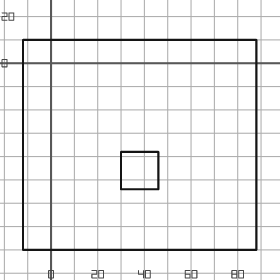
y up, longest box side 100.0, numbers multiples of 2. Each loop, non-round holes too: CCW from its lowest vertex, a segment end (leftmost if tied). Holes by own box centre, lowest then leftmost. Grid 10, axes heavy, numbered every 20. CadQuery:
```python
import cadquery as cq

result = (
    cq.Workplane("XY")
    .moveTo(-12.0, -80.0)
    .lineTo(88.0, -80.0)
    .lineTo(88.0, 10.0)
    .lineTo(-12.0, 10.0)
    .close()
    .moveTo(30.0, -54.0)
    .lineTo(46.0, -54.0)
    .lineTo(46.0, -38.0)
    .lineTo(30.0, -38.0)
    .close()
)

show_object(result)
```